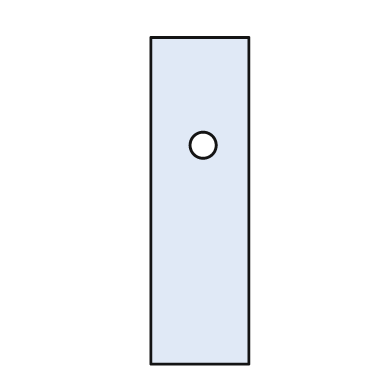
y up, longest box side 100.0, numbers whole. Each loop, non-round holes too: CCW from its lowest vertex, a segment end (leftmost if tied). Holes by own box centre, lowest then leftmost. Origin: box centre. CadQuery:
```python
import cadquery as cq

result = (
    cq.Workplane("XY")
    .moveTo(-15.0, -50.0)
    .lineTo(15.0, -50.0)
    .lineTo(15.0, 50.0)
    .lineTo(-15.0, 50.0)
    .close()
    .moveTo(1.0, 17.0)
    .circle(4.0)
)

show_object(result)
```